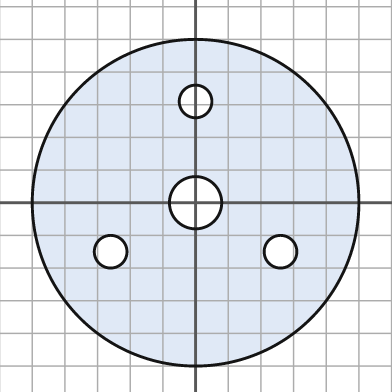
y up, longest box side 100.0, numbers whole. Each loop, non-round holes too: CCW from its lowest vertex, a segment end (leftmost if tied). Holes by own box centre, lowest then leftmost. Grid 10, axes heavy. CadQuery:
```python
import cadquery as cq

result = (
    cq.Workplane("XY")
    .moveTo(0.0, 0.0)
    .circle(50.0)
    .moveTo(-26.0, -15.0)
    .circle(5.0)
    .moveTo(26.0, -15.0)
    .circle(5.0)
    .moveTo(0.0, 0.0)
    .circle(8.0)
    .moveTo(0.0, 31.0)
    .circle(5.0)
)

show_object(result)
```